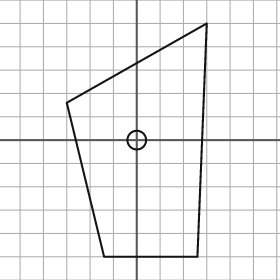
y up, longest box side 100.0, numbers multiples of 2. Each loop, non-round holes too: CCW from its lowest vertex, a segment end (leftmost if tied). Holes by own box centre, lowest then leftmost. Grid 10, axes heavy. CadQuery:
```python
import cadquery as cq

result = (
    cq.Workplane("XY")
    .moveTo(-14.0, -50.0)
    .lineTo(26.0, -50.0)
    .lineTo(30.0, 50.0)
    .lineTo(-30.0, 16.0)
    .close()
    .moveTo(0.0, 0.0)
    .circle(4.0)
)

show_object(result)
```